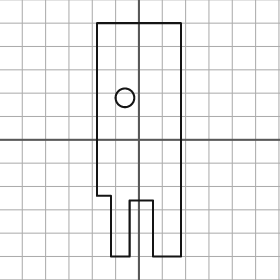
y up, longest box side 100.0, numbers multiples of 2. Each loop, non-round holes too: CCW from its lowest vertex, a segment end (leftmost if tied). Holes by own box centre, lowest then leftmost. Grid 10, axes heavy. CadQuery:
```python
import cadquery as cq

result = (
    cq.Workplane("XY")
    .moveTo(-12.0, -50.0)
    .lineTo(-4.0, -50.0)
    .lineTo(-4.0, -26.0)
    .lineTo(6.0, -26.0)
    .lineTo(6.0, -50.0)
    .lineTo(18.0, -50.0)
    .lineTo(18.0, 50.0)
    .lineTo(-18.0, 50.0)
    .lineTo(-18.0, -24.0)
    .lineTo(-12.0, -24.0)
    .close()
    .moveTo(-6.0, 18.0)
    .circle(4.0)
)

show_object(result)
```